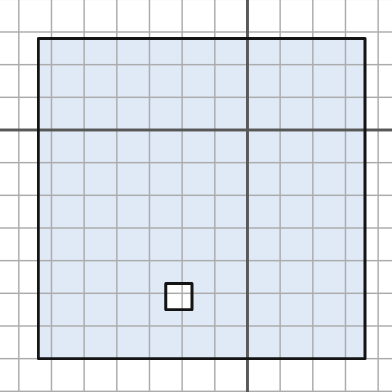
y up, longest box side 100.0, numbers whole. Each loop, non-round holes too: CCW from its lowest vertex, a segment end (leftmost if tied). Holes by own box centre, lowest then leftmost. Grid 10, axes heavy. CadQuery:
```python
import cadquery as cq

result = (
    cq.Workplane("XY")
    .moveTo(-64.0, -70.0)
    .lineTo(36.0, -70.0)
    .lineTo(36.0, 28.0)
    .lineTo(-64.0, 28.0)
    .close()
    .moveTo(-25.0, -55.0)
    .lineTo(-17.0, -55.0)
    .lineTo(-17.0, -47.0)
    .lineTo(-25.0, -47.0)
    .close()
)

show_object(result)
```